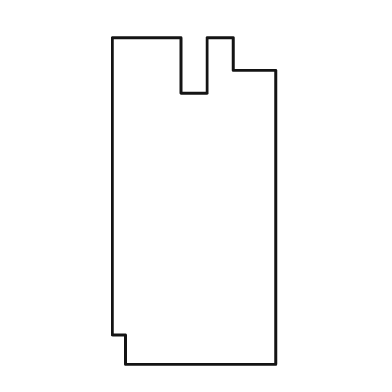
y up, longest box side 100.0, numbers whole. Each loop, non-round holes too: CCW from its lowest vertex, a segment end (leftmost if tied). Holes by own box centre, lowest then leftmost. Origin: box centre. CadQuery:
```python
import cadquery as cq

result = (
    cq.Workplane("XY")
    .moveTo(-21.0, -50.0)
    .lineTo(25.0, -50.0)
    .lineTo(25.0, 40.0)
    .lineTo(12.0, 40.0)
    .lineTo(12.0, 50.0)
    .lineTo(4.0, 50.0)
    .lineTo(4.0, 33.0)
    .lineTo(-4.0, 33.0)
    .lineTo(-4.0, 50.0)
    .lineTo(-25.0, 50.0)
    .lineTo(-25.0, -41.0)
    .lineTo(-21.0, -41.0)
    .close()
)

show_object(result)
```